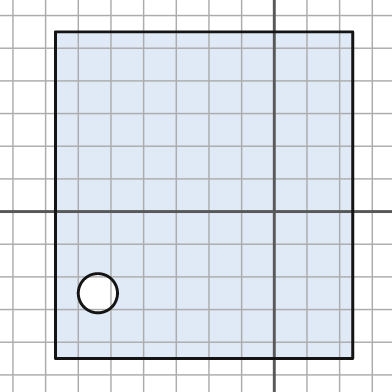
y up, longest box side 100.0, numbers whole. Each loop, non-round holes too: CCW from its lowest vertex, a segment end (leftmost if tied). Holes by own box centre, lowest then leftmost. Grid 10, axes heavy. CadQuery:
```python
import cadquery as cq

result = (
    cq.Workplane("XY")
    .moveTo(-67.0, -45.0)
    .lineTo(24.0, -45.0)
    .lineTo(24.0, 55.0)
    .lineTo(-67.0, 55.0)
    .close()
    .moveTo(-54.0, -25.0)
    .circle(6.0)
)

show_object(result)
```